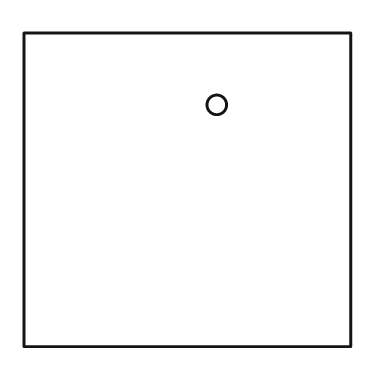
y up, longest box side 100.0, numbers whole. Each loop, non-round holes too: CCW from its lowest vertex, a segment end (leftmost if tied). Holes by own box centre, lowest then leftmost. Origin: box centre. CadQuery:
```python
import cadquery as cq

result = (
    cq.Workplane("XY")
    .moveTo(-50.0, -48.0)
    .lineTo(50.0, -48.0)
    .lineTo(50.0, 48.0)
    .lineTo(-50.0, 48.0)
    .close()
    .moveTo(9.0, 26.0)
    .circle(3.0)
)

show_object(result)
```